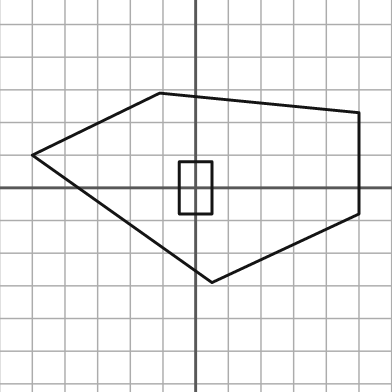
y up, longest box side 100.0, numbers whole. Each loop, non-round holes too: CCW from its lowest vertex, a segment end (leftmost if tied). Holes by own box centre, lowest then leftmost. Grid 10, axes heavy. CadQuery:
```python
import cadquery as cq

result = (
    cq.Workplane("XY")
    .moveTo(5.0, -29.0)
    .lineTo(50.0, -8.0)
    .lineTo(50.0, 23.0)
    .lineTo(-11.0, 29.0)
    .lineTo(-50.0, 10.0)
    .close()
    .moveTo(-5.0, -8.0)
    .lineTo(5.0, -8.0)
    .lineTo(5.0, 8.0)
    .lineTo(-5.0, 8.0)
    .close()
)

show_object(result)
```